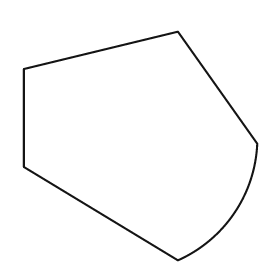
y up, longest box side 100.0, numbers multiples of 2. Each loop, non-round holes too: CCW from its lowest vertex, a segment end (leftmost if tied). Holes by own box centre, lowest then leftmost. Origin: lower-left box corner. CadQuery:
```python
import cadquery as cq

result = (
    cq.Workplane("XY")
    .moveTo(66.0, 0.0)
    .threePointArc((90.0, 20.0), (100.0, 50.0))
    .lineTo(66.0, 98.0)
    .lineTo(0.0, 82.0)
    .lineTo(0.0, 40.0)
    .close()
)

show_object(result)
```